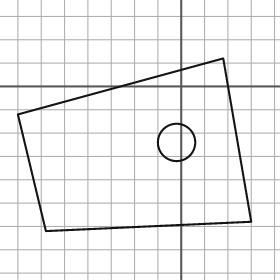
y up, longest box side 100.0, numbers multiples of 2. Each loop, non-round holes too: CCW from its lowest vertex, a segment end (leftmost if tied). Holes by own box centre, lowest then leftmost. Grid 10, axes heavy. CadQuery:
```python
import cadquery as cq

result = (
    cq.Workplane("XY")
    .moveTo(-58.0, -62.0)
    .lineTo(30.0, -58.0)
    .lineTo(18.0, 12.0)
    .lineTo(-70.0, -12.0)
    .close()
    .moveTo(-2.0, -24.0)
    .circle(8.0)
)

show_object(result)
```